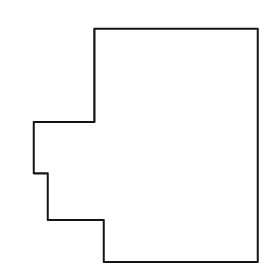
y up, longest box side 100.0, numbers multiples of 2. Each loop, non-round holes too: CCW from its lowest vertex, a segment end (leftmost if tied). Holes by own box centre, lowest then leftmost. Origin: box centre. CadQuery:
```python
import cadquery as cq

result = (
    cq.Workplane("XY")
    .moveTo(-18.0, -50.0)
    .lineTo(48.0, -50.0)
    .lineTo(48.0, 50.0)
    .lineTo(-22.0, 50.0)
    .lineTo(-22.0, 10.0)
    .lineTo(-48.0, 10.0)
    .lineTo(-48.0, -12.0)
    .lineTo(-42.0, -12.0)
    .lineTo(-42.0, -32.0)
    .lineTo(-18.0, -32.0)
    .close()
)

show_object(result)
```